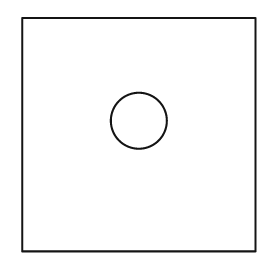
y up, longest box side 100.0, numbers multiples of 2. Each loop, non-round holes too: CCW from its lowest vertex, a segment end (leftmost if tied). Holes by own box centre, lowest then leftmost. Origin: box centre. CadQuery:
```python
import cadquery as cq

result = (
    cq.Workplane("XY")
    .moveTo(-50.0, -50.0)
    .lineTo(50.0, -50.0)
    .lineTo(50.0, 50.0)
    .lineTo(-50.0, 50.0)
    .close()
    .moveTo(0.0, 6.0)
    .circle(12.0)
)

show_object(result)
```